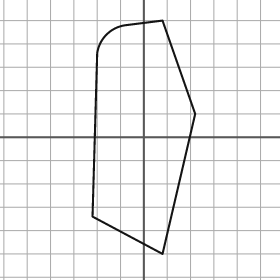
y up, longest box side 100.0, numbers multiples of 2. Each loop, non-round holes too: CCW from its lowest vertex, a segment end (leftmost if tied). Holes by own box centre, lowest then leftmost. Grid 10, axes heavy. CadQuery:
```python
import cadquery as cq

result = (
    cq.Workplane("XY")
    .moveTo(8.0, -50.0)
    .lineTo(22.0, 10.0)
    .lineTo(8.0, 50.0)
    .lineTo(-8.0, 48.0)
    .threePointArc((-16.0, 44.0), (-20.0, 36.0))
    .lineTo(-22.0, -34.0)
    .close()
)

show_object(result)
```